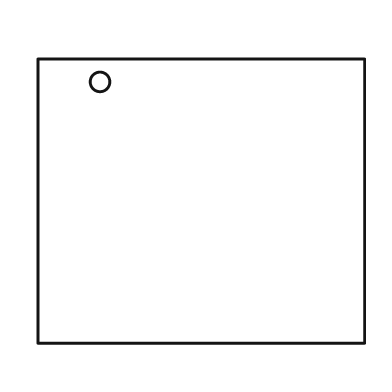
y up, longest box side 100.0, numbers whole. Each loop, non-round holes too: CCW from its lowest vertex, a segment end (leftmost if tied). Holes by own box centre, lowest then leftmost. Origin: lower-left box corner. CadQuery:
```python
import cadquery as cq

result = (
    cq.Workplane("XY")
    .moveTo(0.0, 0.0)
    .lineTo(100.0, 0.0)
    .lineTo(100.0, 87.0)
    .lineTo(0.0, 87.0)
    .close()
    .moveTo(19.0, 80.0)
    .circle(3.0)
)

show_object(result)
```